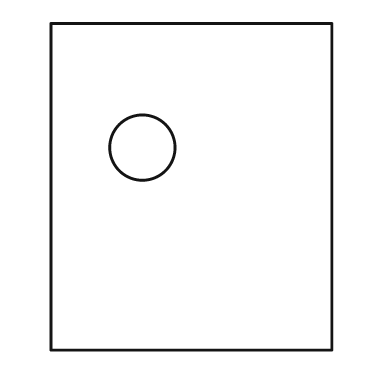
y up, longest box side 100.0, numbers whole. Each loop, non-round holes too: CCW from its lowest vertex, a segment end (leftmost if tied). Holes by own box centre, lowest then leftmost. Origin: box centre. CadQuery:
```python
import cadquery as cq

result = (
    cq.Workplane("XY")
    .moveTo(-43.0, -50.0)
    .lineTo(43.0, -50.0)
    .lineTo(43.0, 50.0)
    .lineTo(-43.0, 50.0)
    .close()
    .moveTo(-15.0, 12.0)
    .circle(10.0)
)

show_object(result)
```